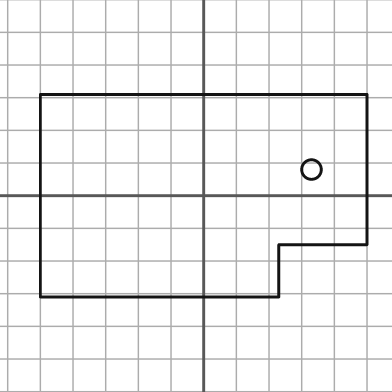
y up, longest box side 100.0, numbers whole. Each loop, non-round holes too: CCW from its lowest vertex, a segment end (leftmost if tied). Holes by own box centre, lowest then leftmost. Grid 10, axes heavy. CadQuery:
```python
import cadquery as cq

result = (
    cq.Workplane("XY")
    .moveTo(-50.0, -31.0)
    .lineTo(23.0, -31.0)
    .lineTo(23.0, -15.0)
    .lineTo(50.0, -15.0)
    .lineTo(50.0, 31.0)
    .lineTo(-50.0, 31.0)
    .close()
    .moveTo(33.0, 8.0)
    .circle(3.0)
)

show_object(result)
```